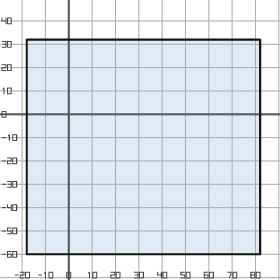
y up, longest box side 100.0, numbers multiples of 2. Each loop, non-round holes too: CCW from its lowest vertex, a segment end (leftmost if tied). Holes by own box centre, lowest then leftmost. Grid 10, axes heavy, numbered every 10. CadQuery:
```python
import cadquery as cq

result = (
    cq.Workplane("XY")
    .moveTo(-18.0, -60.0)
    .lineTo(82.0, -60.0)
    .lineTo(82.0, 32.0)
    .lineTo(-18.0, 32.0)
    .close()
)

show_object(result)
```